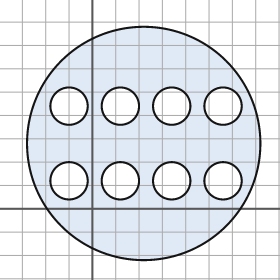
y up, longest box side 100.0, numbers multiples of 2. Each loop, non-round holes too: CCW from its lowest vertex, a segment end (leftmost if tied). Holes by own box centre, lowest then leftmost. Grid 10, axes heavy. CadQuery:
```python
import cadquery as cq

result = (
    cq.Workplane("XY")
    .moveTo(22.0, 28.0)
    .circle(50.0)
    .moveTo(-10.0, 12.0)
    .circle(8.0)
    .moveTo(12.0, 12.0)
    .circle(8.0)
    .moveTo(34.0, 12.0)
    .circle(8.0)
    .moveTo(56.0, 12.0)
    .circle(8.0)
    .moveTo(-10.0, 44.0)
    .circle(8.0)
    .moveTo(12.0, 44.0)
    .circle(8.0)
    .moveTo(34.0, 44.0)
    .circle(8.0)
    .moveTo(56.0, 44.0)
    .circle(8.0)
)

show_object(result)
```